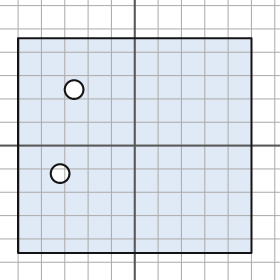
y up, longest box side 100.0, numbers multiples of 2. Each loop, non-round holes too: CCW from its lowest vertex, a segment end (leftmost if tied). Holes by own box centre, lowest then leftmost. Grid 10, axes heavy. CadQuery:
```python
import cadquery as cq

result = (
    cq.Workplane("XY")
    .moveTo(-50.0, -46.0)
    .lineTo(50.0, -46.0)
    .lineTo(50.0, 46.0)
    .lineTo(-50.0, 46.0)
    .close()
    .moveTo(-32.0, -12.0)
    .circle(4.0)
    .moveTo(-26.0, 24.0)
    .circle(4.0)
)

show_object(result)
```